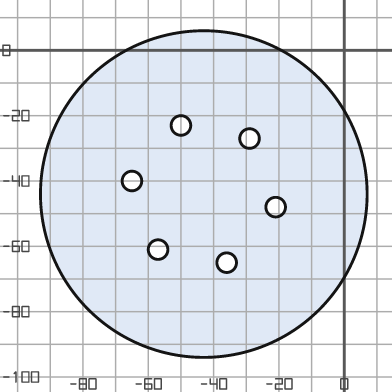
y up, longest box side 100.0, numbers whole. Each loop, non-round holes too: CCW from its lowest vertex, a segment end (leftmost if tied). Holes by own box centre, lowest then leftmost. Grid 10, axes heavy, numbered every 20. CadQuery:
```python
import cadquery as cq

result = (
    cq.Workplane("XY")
    .moveTo(-43.0, -44.0)
    .circle(50.0)
    .moveTo(-36.0, -65.0)
    .circle(3.0)
    .moveTo(-57.0, -61.0)
    .circle(3.0)
    .moveTo(-21.0, -48.0)
    .circle(3.0)
    .moveTo(-65.0, -40.0)
    .circle(3.0)
    .moveTo(-29.0, -27.0)
    .circle(3.0)
    .moveTo(-50.0, -23.0)
    .circle(3.0)
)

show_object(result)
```